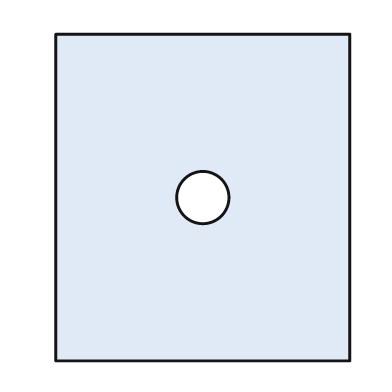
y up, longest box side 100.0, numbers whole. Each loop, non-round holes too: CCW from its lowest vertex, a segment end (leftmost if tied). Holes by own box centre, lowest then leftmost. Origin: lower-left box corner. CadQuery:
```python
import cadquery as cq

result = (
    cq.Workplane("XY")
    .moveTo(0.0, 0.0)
    .lineTo(90.0, 0.0)
    .lineTo(90.0, 100.0)
    .lineTo(0.0, 100.0)
    .close()
    .moveTo(45.0, 50.0)
    .circle(8.0)
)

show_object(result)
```